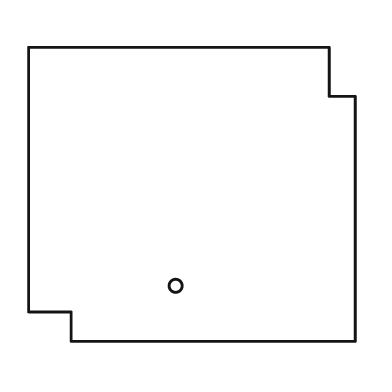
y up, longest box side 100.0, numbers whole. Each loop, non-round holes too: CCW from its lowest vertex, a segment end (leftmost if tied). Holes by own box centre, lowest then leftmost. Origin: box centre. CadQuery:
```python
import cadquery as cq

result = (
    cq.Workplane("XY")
    .moveTo(-37.0, -45.0)
    .lineTo(50.0, -45.0)
    .lineTo(50.0, 30.0)
    .lineTo(42.0, 30.0)
    .lineTo(42.0, 45.0)
    .lineTo(-50.0, 45.0)
    .lineTo(-50.0, -36.0)
    .lineTo(-37.0, -36.0)
    .close()
    .moveTo(-5.0, -28.0)
    .circle(2.0)
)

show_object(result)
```